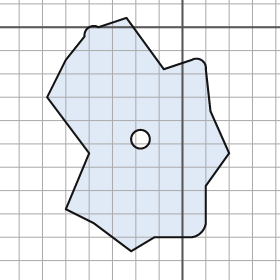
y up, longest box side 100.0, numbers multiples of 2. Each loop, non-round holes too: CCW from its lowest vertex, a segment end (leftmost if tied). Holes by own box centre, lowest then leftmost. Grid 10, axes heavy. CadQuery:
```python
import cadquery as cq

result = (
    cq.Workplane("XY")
    .moveTo(-22.0, -96.0)
    .lineTo(-12.0, -90.0)
    .lineTo(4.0, -90.0)
    .threePointArc((8.0, -88.0), (10.0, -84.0))
    .lineTo(10.0, -68.0)
    .lineTo(20.0, -54.0)
    .lineTo(12.0, -36.0)
    .lineTo(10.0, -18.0)
    .threePointArc((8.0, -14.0), (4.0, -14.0))
    .lineTo(-8.0, -18.0)
    .lineTo(-24.0, 4.0)
    .lineTo(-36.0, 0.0)
    .threePointArc((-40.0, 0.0), (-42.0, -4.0))
    .lineTo(-50.0, -14.0)
    .lineTo(-58.0, -30.0)
    .lineTo(-40.0, -54.0)
    .lineTo(-50.0, -78.0)
    .lineTo(-38.0, -84.0)
    .close()
    .moveTo(-18.0, -48.0)
    .circle(4.0)
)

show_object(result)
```